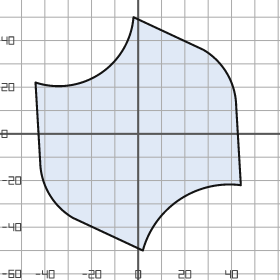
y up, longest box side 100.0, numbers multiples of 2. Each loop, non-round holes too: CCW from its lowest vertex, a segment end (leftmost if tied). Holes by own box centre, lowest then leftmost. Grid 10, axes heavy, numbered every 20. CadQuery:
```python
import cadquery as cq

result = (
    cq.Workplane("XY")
    .moveTo(2.0, -50.0)
    .threePointArc((18.0, -28.0), (44.0, -22.0))
    .lineTo(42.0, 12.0)
    .threePointArc((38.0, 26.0), (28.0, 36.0))
    .lineTo(-2.0, 50.0)
    .threePointArc((-16.0, 26.0), (-44.0, 22.0))
    .lineTo(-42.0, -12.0)
    .threePointArc((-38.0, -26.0), (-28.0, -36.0))
    .close()
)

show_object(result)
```